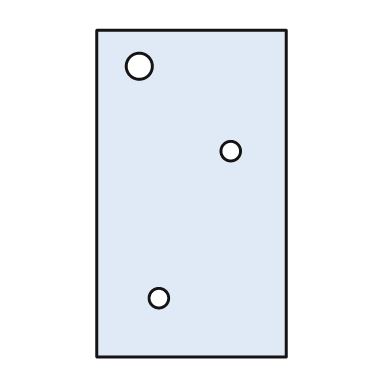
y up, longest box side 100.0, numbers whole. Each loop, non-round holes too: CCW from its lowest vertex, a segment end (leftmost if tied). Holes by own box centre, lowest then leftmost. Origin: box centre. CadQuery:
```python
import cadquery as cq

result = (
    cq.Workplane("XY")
    .moveTo(-29.0, -50.0)
    .lineTo(29.0, -50.0)
    .lineTo(29.0, 50.0)
    .lineTo(-29.0, 50.0)
    .close()
    .moveTo(-10.0, -32.0)
    .circle(3.0)
    .moveTo(12.0, 13.0)
    .circle(3.0)
    .moveTo(-16.0, 39.0)
    .circle(4.0)
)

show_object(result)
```